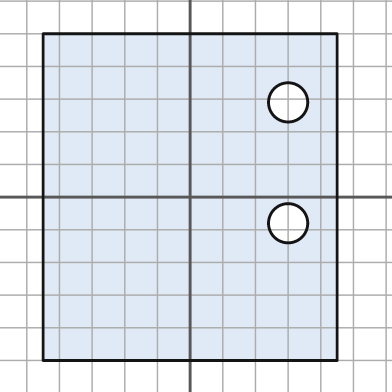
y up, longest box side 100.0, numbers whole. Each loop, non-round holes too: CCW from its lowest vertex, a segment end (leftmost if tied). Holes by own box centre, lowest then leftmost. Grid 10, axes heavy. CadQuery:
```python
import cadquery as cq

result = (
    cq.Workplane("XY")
    .moveTo(-45.0, -50.0)
    .lineTo(45.0, -50.0)
    .lineTo(45.0, 50.0)
    .lineTo(-45.0, 50.0)
    .close()
    .moveTo(30.0, -8.0)
    .circle(6.0)
    .moveTo(30.0, 29.0)
    .circle(6.0)
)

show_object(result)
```